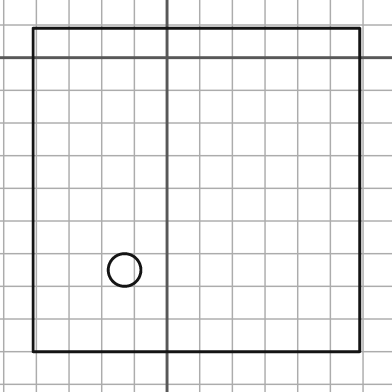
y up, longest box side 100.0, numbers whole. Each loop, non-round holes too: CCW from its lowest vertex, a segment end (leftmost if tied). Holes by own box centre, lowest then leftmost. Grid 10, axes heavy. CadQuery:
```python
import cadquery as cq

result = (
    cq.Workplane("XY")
    .moveTo(-41.0, -90.0)
    .lineTo(59.0, -90.0)
    .lineTo(59.0, 9.0)
    .lineTo(-41.0, 9.0)
    .close()
    .moveTo(-13.0, -65.0)
    .circle(5.0)
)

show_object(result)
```